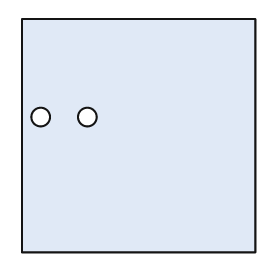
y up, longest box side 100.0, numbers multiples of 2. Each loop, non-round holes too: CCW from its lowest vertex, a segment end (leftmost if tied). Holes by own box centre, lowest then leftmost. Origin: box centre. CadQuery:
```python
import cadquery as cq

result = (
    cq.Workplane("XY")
    .moveTo(-50.0, -50.0)
    .lineTo(50.0, -50.0)
    .lineTo(50.0, 50.0)
    .lineTo(-50.0, 50.0)
    .close()
    .moveTo(-42.0, 8.0)
    .circle(4.0)
    .moveTo(-22.0, 8.0)
    .circle(4.0)
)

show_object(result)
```